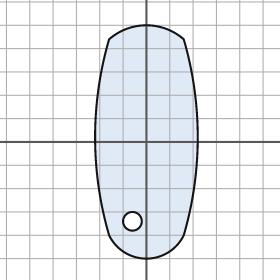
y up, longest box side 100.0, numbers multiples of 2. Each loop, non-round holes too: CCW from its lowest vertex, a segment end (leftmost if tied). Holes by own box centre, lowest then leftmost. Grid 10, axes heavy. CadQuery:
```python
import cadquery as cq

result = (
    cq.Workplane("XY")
    .moveTo(-16.0, -40.0)
    .threePointArc((0.0, -50.0), (16.0, -40.0))
    .threePointArc((22.0, 2.0), (16.0, 44.0))
    .threePointArc((0.0, 50.0), (-16.0, 44.0))
    .threePointArc((-22.0, 2.0), (-16.0, -40.0))
    .close()
    .moveTo(-6.0, -34.0)
    .circle(4.0)
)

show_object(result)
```